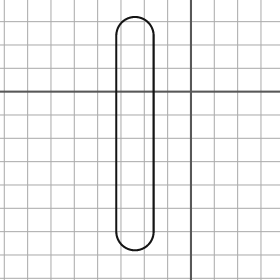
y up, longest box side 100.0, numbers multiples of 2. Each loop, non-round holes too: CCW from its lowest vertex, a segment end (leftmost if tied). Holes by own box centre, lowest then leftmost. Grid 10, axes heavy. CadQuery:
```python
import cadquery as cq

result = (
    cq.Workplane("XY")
    .moveTo(-32.0, -60.0)
    .threePointArc((-24.0, -68.0), (-16.0, -60.0))
    .lineTo(-16.0, 24.0)
    .threePointArc((-24.0, 32.0), (-32.0, 24.0))
    .close()
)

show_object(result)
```